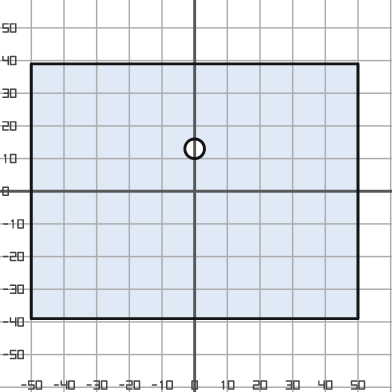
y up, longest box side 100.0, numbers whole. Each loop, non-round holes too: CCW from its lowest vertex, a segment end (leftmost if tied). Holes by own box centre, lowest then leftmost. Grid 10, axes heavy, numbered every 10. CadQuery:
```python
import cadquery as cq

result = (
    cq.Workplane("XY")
    .moveTo(-50.0, -39.0)
    .lineTo(50.0, -39.0)
    .lineTo(50.0, 39.0)
    .lineTo(-50.0, 39.0)
    .close()
    .moveTo(0.0, 13.0)
    .circle(3.0)
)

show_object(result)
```